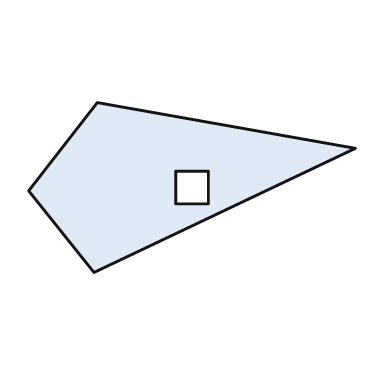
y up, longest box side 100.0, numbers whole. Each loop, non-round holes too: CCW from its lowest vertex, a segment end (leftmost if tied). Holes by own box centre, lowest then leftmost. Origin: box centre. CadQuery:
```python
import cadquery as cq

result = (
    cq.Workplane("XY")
    .moveTo(-30.0, -26.0)
    .lineTo(50.0, 12.0)
    .lineTo(-29.0, 26.0)
    .lineTo(-50.0, -1.0)
    .close()
    .moveTo(-5.0, -5.0)
    .lineTo(5.0, -5.0)
    .lineTo(5.0, 5.0)
    .lineTo(-5.0, 5.0)
    .close()
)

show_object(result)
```